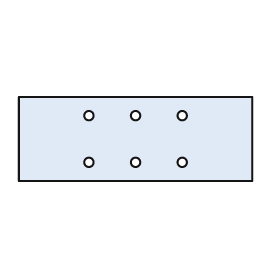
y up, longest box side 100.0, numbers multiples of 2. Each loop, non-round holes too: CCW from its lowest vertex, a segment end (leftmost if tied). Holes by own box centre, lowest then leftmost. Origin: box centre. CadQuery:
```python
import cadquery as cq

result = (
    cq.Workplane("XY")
    .moveTo(-50.0, -18.0)
    .lineTo(50.0, -18.0)
    .lineTo(50.0, 18.0)
    .lineTo(-50.0, 18.0)
    .close()
    .moveTo(-20.0, -10.0)
    .circle(2.0)
    .moveTo(0.0, -10.0)
    .circle(2.0)
    .moveTo(20.0, -10.0)
    .circle(2.0)
    .moveTo(-20.0, 10.0)
    .circle(2.0)
    .moveTo(0.0, 10.0)
    .circle(2.0)
    .moveTo(20.0, 10.0)
    .circle(2.0)
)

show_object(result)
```